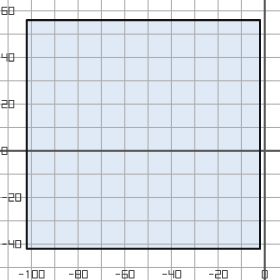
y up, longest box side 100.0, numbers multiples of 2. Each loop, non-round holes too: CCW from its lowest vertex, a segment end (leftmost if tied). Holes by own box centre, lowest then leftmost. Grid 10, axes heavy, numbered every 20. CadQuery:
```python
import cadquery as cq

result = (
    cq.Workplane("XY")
    .moveTo(-102.0, -42.0)
    .lineTo(-2.0, -42.0)
    .lineTo(-2.0, 56.0)
    .lineTo(-102.0, 56.0)
    .close()
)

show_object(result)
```